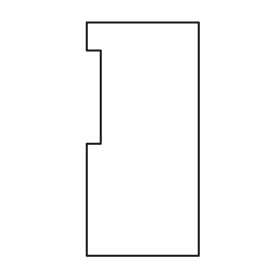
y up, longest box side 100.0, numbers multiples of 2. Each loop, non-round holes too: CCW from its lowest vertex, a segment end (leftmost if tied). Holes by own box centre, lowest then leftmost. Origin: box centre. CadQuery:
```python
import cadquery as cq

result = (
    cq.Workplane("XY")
    .moveTo(-24.0, -50.0)
    .lineTo(24.0, -50.0)
    .lineTo(24.0, 50.0)
    .lineTo(-24.0, 50.0)
    .lineTo(-24.0, 38.0)
    .lineTo(-18.0, 38.0)
    .lineTo(-18.0, -2.0)
    .lineTo(-24.0, -2.0)
    .close()
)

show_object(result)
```